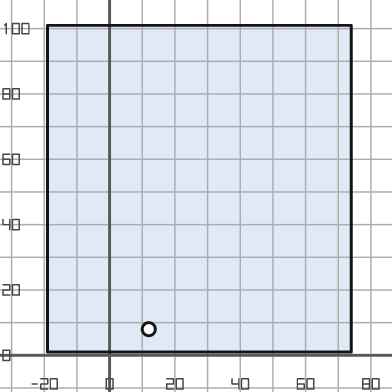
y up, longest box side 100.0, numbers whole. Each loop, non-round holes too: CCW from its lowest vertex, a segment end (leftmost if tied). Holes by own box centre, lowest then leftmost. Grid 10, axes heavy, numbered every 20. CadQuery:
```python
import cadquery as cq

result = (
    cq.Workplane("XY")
    .moveTo(-19.0, 1.0)
    .lineTo(74.0, 1.0)
    .lineTo(74.0, 101.0)
    .lineTo(-19.0, 101.0)
    .close()
    .moveTo(12.0, 8.0)
    .circle(2.0)
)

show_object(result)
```